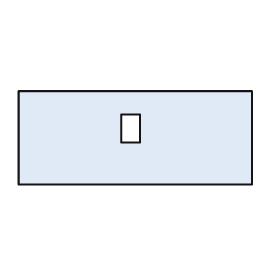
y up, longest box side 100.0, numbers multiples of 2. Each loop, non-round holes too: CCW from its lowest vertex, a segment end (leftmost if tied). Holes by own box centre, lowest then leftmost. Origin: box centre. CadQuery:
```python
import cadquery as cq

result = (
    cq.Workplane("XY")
    .moveTo(-50.0, -20.0)
    .lineTo(50.0, -20.0)
    .lineTo(50.0, 20.0)
    .lineTo(-50.0, 20.0)
    .close()
    .moveTo(-6.0, -2.0)
    .lineTo(2.0, -2.0)
    .lineTo(2.0, 10.0)
    .lineTo(-6.0, 10.0)
    .close()
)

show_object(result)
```